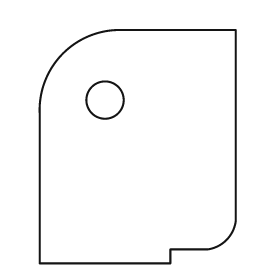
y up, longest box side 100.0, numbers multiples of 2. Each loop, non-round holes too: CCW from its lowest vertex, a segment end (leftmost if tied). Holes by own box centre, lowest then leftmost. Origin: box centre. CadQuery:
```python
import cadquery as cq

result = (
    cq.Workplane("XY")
    .moveTo(-42.0, -50.0)
    .lineTo(14.0, -50.0)
    .lineTo(14.0, -44.0)
    .lineTo(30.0, -44.0)
    .threePointArc((38.0, -40.0), (42.0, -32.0))
    .lineTo(42.0, 50.0)
    .lineTo(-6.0, 50.0)
    .threePointArc((-32.0, 40.0), (-42.0, 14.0))
    .close()
    .moveTo(-14.0, 20.0)
    .circle(8.0)
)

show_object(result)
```